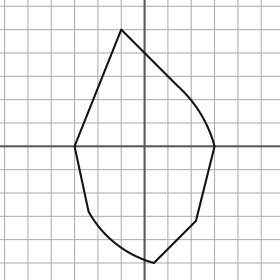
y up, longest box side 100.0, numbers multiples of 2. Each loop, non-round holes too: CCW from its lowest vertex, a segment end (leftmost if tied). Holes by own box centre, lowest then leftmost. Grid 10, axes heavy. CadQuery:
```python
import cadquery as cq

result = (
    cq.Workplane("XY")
    .moveTo(4.0, -50.0)
    .lineTo(22.0, -32.0)
    .lineTo(30.0, 0.0)
    .threePointArc((24.0, 14.0), (14.0, 26.0))
    .lineTo(-10.0, 50.0)
    .lineTo(-30.0, 0.0)
    .lineTo(-24.0, -28.0)
    .threePointArc((-12.0, -42.0), (4.0, -50.0))
    .close()
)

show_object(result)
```